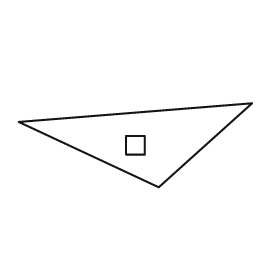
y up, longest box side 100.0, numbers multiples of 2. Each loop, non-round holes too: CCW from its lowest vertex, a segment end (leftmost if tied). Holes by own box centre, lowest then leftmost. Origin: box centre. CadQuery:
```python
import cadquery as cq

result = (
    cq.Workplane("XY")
    .moveTo(10.0, -18.0)
    .lineTo(50.0, 18.0)
    .lineTo(-50.0, 10.0)
    .close()
    .moveTo(-4.0, -4.0)
    .lineTo(4.0, -4.0)
    .lineTo(4.0, 4.0)
    .lineTo(-4.0, 4.0)
    .close()
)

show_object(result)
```